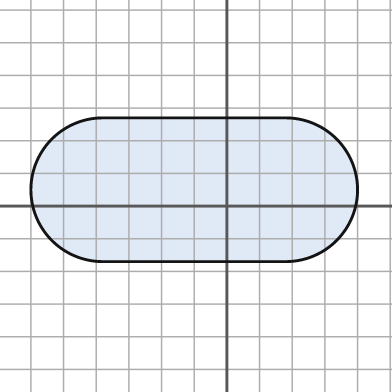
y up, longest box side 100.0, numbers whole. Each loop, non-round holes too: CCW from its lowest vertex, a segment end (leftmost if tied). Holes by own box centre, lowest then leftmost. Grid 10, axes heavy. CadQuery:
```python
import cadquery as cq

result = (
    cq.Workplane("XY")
    .moveTo(-38.0, -17.0)
    .lineTo(18.0, -17.0)
    .threePointArc((40.0, 5.0), (18.0, 27.0))
    .lineTo(-38.0, 27.0)
    .threePointArc((-60.0, 5.0), (-38.0, -17.0))
    .close()
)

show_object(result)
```